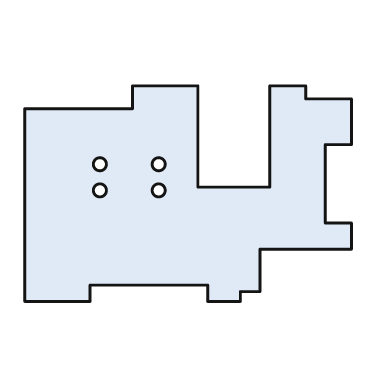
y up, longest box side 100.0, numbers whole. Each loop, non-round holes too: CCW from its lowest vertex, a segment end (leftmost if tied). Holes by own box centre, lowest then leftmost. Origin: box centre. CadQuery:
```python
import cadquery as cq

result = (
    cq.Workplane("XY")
    .moveTo(-50.0, -33.0)
    .lineTo(-30.0, -33.0)
    .lineTo(-30.0, -28.0)
    .lineTo(6.0, -28.0)
    .lineTo(6.0, -33.0)
    .lineTo(16.0, -33.0)
    .lineTo(16.0, -30.0)
    .lineTo(22.0, -30.0)
    .lineTo(22.0, -17.0)
    .lineTo(50.0, -17.0)
    .lineTo(50.0, -9.0)
    .lineTo(42.0, -9.0)
    .lineTo(42.0, 15.0)
    .lineTo(50.0, 15.0)
    .lineTo(50.0, 29.0)
    .lineTo(36.0, 29.0)
    .lineTo(36.0, 33.0)
    .lineTo(25.0, 33.0)
    .lineTo(25.0, 2.0)
    .lineTo(3.0, 2.0)
    .lineTo(3.0, 33.0)
    .lineTo(-17.0, 33.0)
    .lineTo(-17.0, 26.0)
    .lineTo(-50.0, 26.0)
    .close()
    .moveTo(-27.0, 1.0)
    .circle(2.0)
    .moveTo(-9.0, 1.0)
    .circle(2.0)
    .moveTo(-27.0, 9.0)
    .circle(2.0)
    .moveTo(-9.0, 9.0)
    .circle(2.0)
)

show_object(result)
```